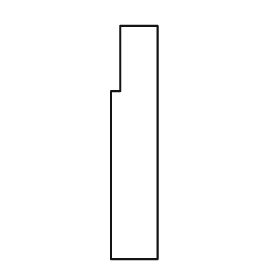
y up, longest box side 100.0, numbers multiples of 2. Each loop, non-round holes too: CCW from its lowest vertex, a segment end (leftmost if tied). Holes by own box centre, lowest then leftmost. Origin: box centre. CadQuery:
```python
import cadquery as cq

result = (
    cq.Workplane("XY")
    .moveTo(-10.0, -50.0)
    .lineTo(10.0, -50.0)
    .lineTo(10.0, 50.0)
    .lineTo(-6.0, 50.0)
    .lineTo(-6.0, 22.0)
    .lineTo(-10.0, 22.0)
    .close()
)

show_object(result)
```